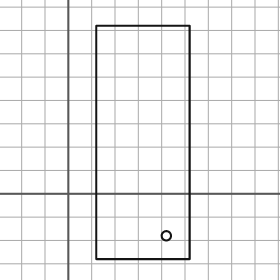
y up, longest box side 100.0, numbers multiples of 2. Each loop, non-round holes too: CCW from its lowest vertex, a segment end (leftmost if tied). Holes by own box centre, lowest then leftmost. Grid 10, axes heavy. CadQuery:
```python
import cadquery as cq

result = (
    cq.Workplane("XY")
    .moveTo(12.0, -28.0)
    .lineTo(52.0, -28.0)
    .lineTo(52.0, 72.0)
    .lineTo(12.0, 72.0)
    .close()
    .moveTo(42.0, -18.0)
    .circle(2.0)
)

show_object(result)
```